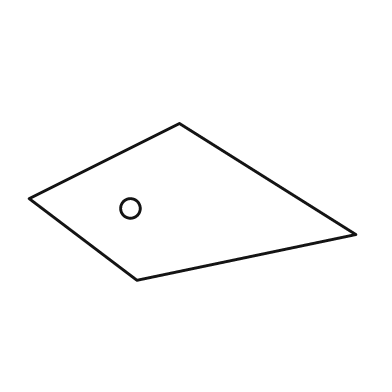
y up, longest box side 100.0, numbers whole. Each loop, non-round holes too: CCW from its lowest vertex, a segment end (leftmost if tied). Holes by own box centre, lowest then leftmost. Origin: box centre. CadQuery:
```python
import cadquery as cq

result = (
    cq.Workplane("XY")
    .moveTo(-17.0, -24.0)
    .lineTo(50.0, -10.0)
    .lineTo(-4.0, 24.0)
    .lineTo(-50.0, 1.0)
    .close()
    .moveTo(-19.0, -2.0)
    .circle(3.0)
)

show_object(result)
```